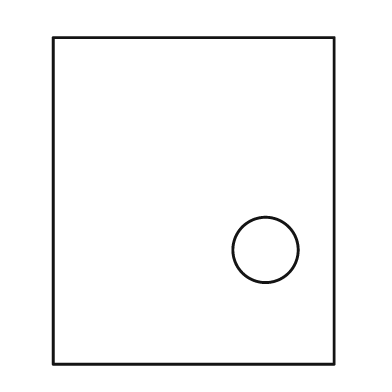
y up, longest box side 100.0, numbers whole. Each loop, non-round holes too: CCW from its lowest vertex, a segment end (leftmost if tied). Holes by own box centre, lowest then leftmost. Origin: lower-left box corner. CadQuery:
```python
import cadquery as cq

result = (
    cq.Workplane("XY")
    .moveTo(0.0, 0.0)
    .lineTo(86.0, 0.0)
    .lineTo(86.0, 100.0)
    .lineTo(0.0, 100.0)
    .close()
    .moveTo(65.0, 35.0)
    .circle(10.0)
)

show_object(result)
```